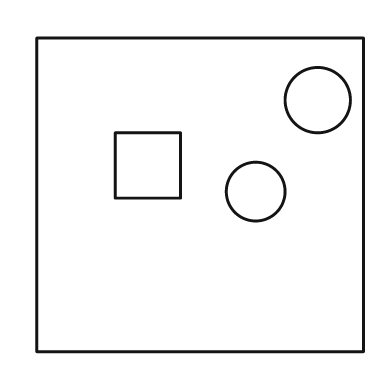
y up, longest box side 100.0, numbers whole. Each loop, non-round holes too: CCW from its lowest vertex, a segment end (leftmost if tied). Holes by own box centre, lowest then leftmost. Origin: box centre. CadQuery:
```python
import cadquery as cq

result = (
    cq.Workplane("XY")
    .moveTo(-50.0, -48.0)
    .lineTo(50.0, -48.0)
    .lineTo(50.0, 48.0)
    .lineTo(-50.0, 48.0)
    .close()
    .moveTo(17.0, 1.0)
    .circle(9.0)
    .moveTo(-26.0, -1.0)
    .lineTo(-6.0, -1.0)
    .lineTo(-6.0, 19.0)
    .lineTo(-26.0, 19.0)
    .close()
    .moveTo(36.0, 29.0)
    .circle(10.0)
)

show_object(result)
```